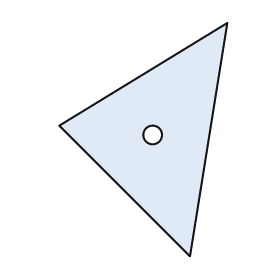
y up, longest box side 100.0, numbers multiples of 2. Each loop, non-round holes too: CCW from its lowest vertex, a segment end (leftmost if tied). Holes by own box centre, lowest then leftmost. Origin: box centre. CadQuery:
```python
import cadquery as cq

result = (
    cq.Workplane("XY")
    .moveTo(20.0, -50.0)
    .lineTo(36.0, 50.0)
    .lineTo(-36.0, 6.0)
    .close()
    .moveTo(4.0, 2.0)
    .circle(4.0)
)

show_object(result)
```